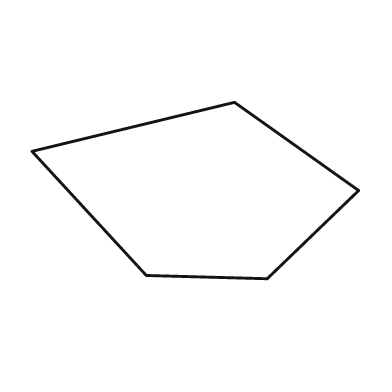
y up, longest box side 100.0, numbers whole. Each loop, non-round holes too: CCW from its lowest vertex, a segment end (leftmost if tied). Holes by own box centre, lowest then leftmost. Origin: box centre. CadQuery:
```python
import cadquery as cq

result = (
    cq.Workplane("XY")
    .moveTo(22.0, -27.0)
    .lineTo(50.0, 0.0)
    .lineTo(12.0, 27.0)
    .lineTo(-50.0, 12.0)
    .lineTo(-15.0, -26.0)
    .close()
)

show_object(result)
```